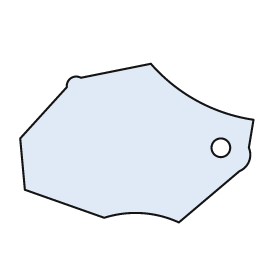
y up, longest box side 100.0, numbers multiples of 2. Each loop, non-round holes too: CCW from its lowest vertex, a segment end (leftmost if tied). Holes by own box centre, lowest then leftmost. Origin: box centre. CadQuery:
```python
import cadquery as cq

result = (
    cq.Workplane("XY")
    .moveTo(18.0, -34.0)
    .lineTo(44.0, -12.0)
    .threePointArc((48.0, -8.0), (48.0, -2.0))
    .lineTo(50.0, 10.0)
    .threePointArc((26.0, 18.0), (6.0, 34.0))
    .lineTo(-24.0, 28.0)
    .threePointArc((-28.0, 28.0), (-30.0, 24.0))
    .lineTo(-50.0, 2.0)
    .lineTo(-48.0, -20.0)
    .lineTo(-14.0, -32.0)
    .threePointArc((2.0, -30.0), (18.0, -34.0))
    .close()
    .moveTo(36.0, -2.0)
    .circle(4.0)
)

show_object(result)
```